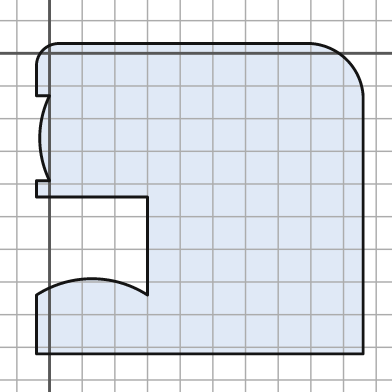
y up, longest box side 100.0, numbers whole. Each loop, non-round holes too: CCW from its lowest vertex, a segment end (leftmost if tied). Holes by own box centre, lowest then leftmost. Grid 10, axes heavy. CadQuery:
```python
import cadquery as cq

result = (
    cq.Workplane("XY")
    .moveTo(-4.0, -92.0)
    .lineTo(96.0, -92.0)
    .lineTo(96.0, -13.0)
    .threePointArc((91.0, -2.0), (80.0, 3.0))
    .lineTo(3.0, 3.0)
    .threePointArc((-2.0, 1.0), (-4.0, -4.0))
    .lineTo(-4.0, -13.0)
    .lineTo(0.0, -13.0)
    .threePointArc((-3.0, -26.0), (0.0, -39.0))
    .lineTo(-4.0, -39.0)
    .lineTo(-4.0, -44.0)
    .lineTo(30.0, -44.0)
    .lineTo(30.0, -74.0)
    .threePointArc((13.0, -69.0), (-4.0, -74.0))
    .close()
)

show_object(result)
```